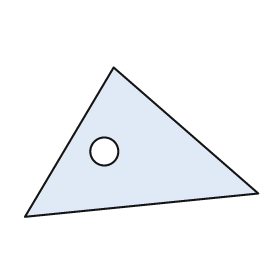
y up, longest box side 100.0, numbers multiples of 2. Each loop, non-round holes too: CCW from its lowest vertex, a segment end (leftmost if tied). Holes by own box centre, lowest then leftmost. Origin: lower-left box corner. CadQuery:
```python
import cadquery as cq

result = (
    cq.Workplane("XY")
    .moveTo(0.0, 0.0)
    .lineTo(100.0, 10.0)
    .lineTo(38.0, 64.0)
    .close()
    .moveTo(34.0, 28.0)
    .circle(6.0)
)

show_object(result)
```